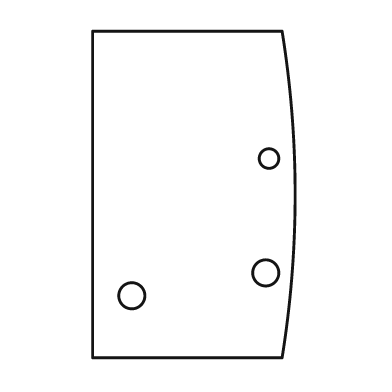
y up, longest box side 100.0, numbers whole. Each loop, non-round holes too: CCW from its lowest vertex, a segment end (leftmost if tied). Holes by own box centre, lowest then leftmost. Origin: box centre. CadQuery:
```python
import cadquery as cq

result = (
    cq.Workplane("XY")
    .moveTo(-31.0, -50.0)
    .lineTo(27.0, -50.0)
    .threePointArc((31.0, 0.0), (27.0, 50.0))
    .lineTo(-31.0, 50.0)
    .close()
    .moveTo(-19.0, -31.0)
    .circle(4.0)
    .moveTo(22.0, -24.0)
    .circle(4.0)
    .moveTo(23.0, 11.0)
    .circle(3.0)
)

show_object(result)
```